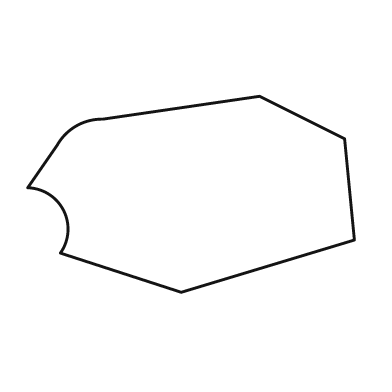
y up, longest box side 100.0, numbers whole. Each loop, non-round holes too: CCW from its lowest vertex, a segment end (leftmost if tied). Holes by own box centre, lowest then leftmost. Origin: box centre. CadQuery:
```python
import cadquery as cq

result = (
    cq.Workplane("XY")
    .moveTo(-3.0, -30.0)
    .lineTo(50.0, -14.0)
    .lineTo(47.0, 17.0)
    .lineTo(21.0, 30.0)
    .lineTo(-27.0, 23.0)
    .threePointArc((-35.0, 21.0), (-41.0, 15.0))
    .lineTo(-50.0, 2.0)
    .threePointArc((-39.0, -5.0), (-40.0, -18.0))
    .close()
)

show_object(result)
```